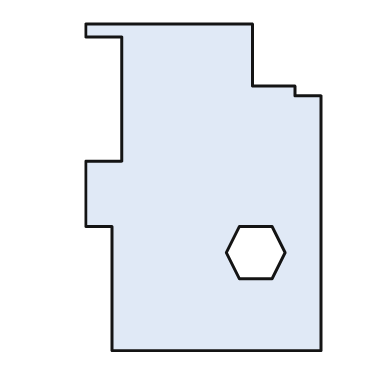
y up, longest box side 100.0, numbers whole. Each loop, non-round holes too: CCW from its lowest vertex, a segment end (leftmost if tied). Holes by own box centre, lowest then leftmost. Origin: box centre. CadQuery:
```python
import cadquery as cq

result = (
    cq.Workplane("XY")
    .moveTo(-28.0, -50.0)
    .lineTo(36.0, -50.0)
    .lineTo(36.0, 28.0)
    .lineTo(28.0, 28.0)
    .lineTo(28.0, 31.0)
    .lineTo(15.0, 31.0)
    .lineTo(15.0, 50.0)
    .lineTo(-36.0, 50.0)
    .lineTo(-36.0, 46.0)
    .lineTo(-25.0, 46.0)
    .lineTo(-25.0, 8.0)
    .lineTo(-36.0, 8.0)
    .lineTo(-36.0, -12.0)
    .lineTo(-28.0, -12.0)
    .close()
    .moveTo(11.0, -28.0)
    .lineTo(21.0, -28.0)
    .lineTo(25.0, -20.0)
    .lineTo(21.0, -12.0)
    .lineTo(11.0, -12.0)
    .lineTo(7.0, -20.0)
    .close()
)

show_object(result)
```